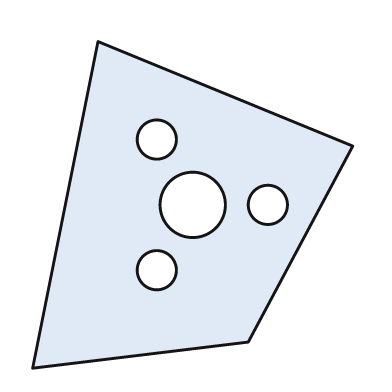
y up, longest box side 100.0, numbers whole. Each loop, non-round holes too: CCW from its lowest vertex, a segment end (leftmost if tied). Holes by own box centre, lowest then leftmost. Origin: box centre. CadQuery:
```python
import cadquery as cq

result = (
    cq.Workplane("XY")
    .moveTo(-49.0, -50.0)
    .lineTo(17.0, -42.0)
    .lineTo(49.0, 18.0)
    .lineTo(-29.0, 50.0)
    .close()
    .moveTo(-11.0, -20.0)
    .circle(6.0)
    .moveTo(0.0, 0.0)
    .circle(10.0)
    .moveTo(23.0, 0.0)
    .circle(6.0)
    .moveTo(-11.0, 20.0)
    .circle(6.0)
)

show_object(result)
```